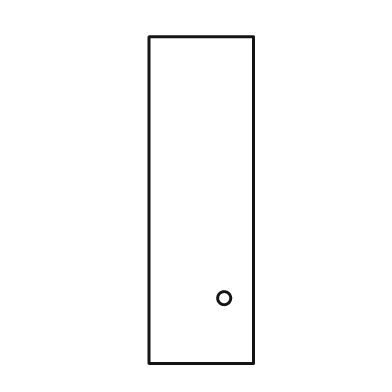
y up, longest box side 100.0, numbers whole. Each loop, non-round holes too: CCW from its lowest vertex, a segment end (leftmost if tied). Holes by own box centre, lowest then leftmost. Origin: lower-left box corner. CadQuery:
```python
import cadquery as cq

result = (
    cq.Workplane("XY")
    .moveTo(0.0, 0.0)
    .lineTo(32.0, 0.0)
    .lineTo(32.0, 100.0)
    .lineTo(0.0, 100.0)
    .close()
    .moveTo(23.0, 20.0)
    .circle(2.0)
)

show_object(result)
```